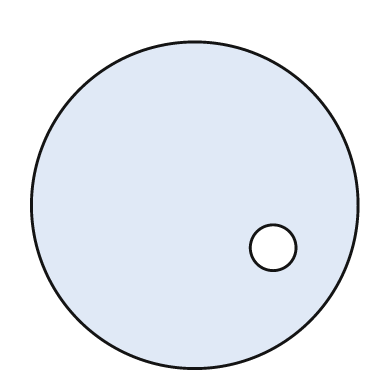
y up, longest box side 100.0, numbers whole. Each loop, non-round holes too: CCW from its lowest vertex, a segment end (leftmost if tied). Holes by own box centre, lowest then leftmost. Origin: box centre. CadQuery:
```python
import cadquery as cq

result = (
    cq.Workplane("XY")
    .moveTo(0.0, 0.0)
    .circle(50.0)
    .moveTo(24.0, -13.0)
    .circle(7.0)
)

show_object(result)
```